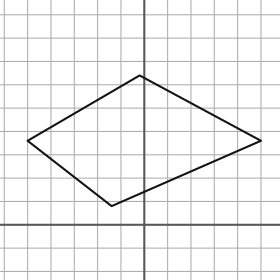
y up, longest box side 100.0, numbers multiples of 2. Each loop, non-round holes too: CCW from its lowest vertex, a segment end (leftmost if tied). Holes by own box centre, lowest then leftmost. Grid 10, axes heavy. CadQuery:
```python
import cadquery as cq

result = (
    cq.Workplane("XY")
    .moveTo(-14.0, 8.0)
    .lineTo(50.0, 36.0)
    .lineTo(-2.0, 64.0)
    .lineTo(-50.0, 36.0)
    .close()
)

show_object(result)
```